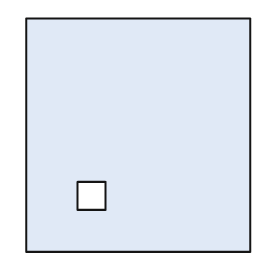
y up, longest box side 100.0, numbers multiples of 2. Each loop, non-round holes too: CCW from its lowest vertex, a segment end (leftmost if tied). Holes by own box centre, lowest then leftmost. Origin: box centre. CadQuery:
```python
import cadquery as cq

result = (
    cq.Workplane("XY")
    .moveTo(-48.0, -50.0)
    .lineTo(48.0, -50.0)
    .lineTo(48.0, 50.0)
    .lineTo(-48.0, 50.0)
    .close()
    .moveTo(-26.0, -32.0)
    .lineTo(-14.0, -32.0)
    .lineTo(-14.0, -20.0)
    .lineTo(-26.0, -20.0)
    .close()
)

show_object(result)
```